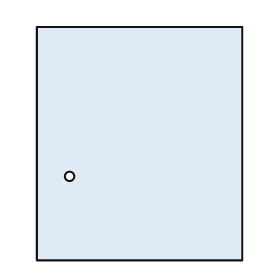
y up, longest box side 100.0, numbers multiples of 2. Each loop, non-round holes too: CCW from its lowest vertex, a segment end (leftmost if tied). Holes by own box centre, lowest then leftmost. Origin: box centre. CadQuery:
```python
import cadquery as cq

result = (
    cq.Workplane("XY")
    .moveTo(-44.0, -50.0)
    .lineTo(44.0, -50.0)
    .lineTo(44.0, 50.0)
    .lineTo(-44.0, 50.0)
    .close()
    .moveTo(-30.0, -14.0)
    .circle(2.0)
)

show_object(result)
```